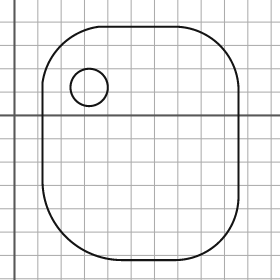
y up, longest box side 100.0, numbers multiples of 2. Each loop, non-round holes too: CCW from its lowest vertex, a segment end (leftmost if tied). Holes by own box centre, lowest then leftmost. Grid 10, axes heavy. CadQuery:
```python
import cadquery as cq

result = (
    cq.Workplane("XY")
    .moveTo(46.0, -62.0)
    .lineTo(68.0, -62.0)
    .threePointArc((88.0, -54.0), (96.0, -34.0))
    .lineTo(96.0, 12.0)
    .threePointArc((88.0, 30.0), (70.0, 38.0))
    .lineTo(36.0, 38.0)
    .threePointArc((20.0, 30.0), (12.0, 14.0))
    .lineTo(12.0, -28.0)
    .threePointArc((22.0, -52.0), (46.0, -62.0))
    .close()
    .moveTo(32.0, 12.0)
    .circle(8.0)
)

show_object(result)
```